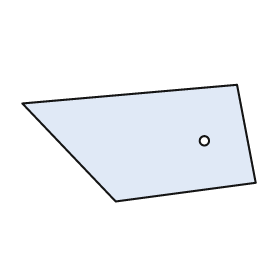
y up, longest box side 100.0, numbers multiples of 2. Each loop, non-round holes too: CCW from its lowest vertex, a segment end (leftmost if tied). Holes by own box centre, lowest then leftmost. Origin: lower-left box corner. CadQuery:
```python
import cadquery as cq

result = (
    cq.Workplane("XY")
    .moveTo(40.0, 0.0)
    .lineTo(100.0, 8.0)
    .lineTo(92.0, 50.0)
    .lineTo(0.0, 42.0)
    .close()
    .moveTo(78.0, 26.0)
    .circle(2.0)
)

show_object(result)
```